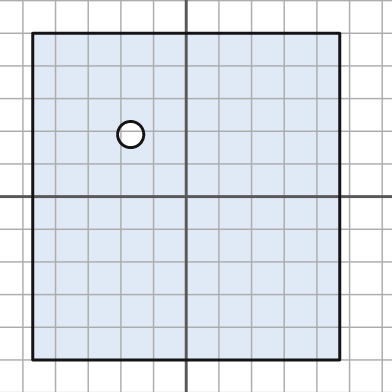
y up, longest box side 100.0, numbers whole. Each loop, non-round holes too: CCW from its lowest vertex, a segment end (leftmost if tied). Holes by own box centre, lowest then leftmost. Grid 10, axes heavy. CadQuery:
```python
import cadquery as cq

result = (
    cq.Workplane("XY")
    .moveTo(-47.0, -50.0)
    .lineTo(47.0, -50.0)
    .lineTo(47.0, 50.0)
    .lineTo(-47.0, 50.0)
    .close()
    .moveTo(-17.0, 19.0)
    .circle(4.0)
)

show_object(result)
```